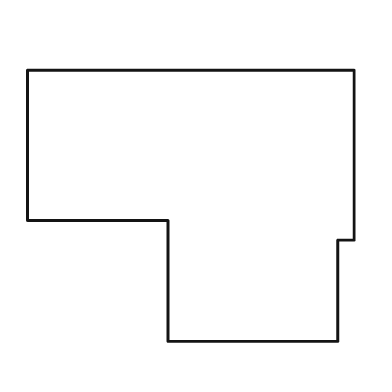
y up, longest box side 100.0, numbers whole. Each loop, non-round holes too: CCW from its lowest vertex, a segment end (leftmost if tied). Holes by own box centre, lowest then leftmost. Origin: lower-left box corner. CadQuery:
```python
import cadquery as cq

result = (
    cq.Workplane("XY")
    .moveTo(43.0, 0.0)
    .lineTo(95.0, 0.0)
    .lineTo(95.0, 31.0)
    .lineTo(100.0, 31.0)
    .lineTo(100.0, 83.0)
    .lineTo(0.0, 83.0)
    .lineTo(0.0, 37.0)
    .lineTo(43.0, 37.0)
    .close()
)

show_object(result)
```